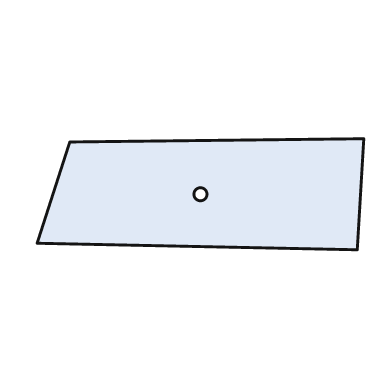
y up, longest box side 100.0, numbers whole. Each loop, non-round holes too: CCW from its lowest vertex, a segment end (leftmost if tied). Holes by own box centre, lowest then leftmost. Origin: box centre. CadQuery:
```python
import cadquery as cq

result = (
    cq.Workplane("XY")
    .moveTo(48.0, -17.0)
    .lineTo(50.0, 17.0)
    .lineTo(-40.0, 16.0)
    .lineTo(-50.0, -15.0)
    .close()
    .moveTo(0.0, 0.0)
    .circle(2.0)
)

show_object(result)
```